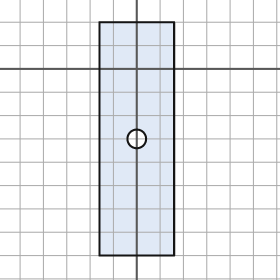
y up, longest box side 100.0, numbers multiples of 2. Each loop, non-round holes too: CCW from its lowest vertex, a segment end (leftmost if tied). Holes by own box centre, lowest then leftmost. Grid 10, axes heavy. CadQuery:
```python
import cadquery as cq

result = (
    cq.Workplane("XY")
    .moveTo(-16.0, -80.0)
    .lineTo(16.0, -80.0)
    .lineTo(16.0, 20.0)
    .lineTo(-16.0, 20.0)
    .close()
    .moveTo(0.0, -30.0)
    .circle(4.0)
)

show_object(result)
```